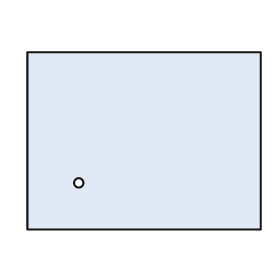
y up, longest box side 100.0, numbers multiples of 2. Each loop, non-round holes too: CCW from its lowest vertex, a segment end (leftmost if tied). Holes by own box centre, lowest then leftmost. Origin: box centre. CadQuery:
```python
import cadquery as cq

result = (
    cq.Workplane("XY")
    .moveTo(-50.0, -38.0)
    .lineTo(50.0, -38.0)
    .lineTo(50.0, 38.0)
    .lineTo(-50.0, 38.0)
    .close()
    .moveTo(-28.0, -18.0)
    .circle(2.0)
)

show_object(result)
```